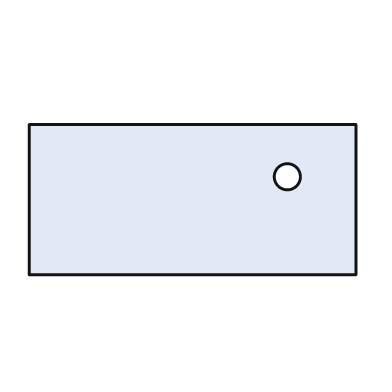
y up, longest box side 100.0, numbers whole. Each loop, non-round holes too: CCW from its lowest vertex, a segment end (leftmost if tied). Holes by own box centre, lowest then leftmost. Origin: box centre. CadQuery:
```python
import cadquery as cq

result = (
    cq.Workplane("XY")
    .moveTo(-50.0, -23.0)
    .lineTo(50.0, -23.0)
    .lineTo(50.0, 23.0)
    .lineTo(-50.0, 23.0)
    .close()
    .moveTo(29.0, 7.0)
    .circle(4.0)
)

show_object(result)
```